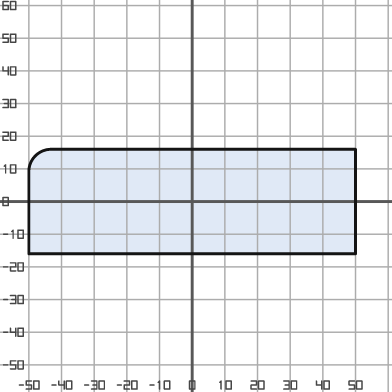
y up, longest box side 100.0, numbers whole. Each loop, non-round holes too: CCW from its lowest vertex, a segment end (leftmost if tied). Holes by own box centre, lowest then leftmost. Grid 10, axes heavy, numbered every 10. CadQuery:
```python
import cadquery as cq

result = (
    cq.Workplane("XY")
    .moveTo(-50.0, -16.0)
    .lineTo(50.0, -16.0)
    .lineTo(50.0, 16.0)
    .lineTo(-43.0, 16.0)
    .threePointArc((-48.0, 14.0), (-50.0, 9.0))
    .close()
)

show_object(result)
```